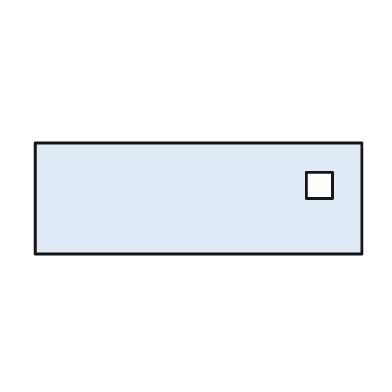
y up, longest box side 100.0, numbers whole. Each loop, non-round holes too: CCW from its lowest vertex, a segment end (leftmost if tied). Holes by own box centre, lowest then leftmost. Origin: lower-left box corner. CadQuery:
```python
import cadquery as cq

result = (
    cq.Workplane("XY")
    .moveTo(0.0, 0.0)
    .lineTo(100.0, 0.0)
    .lineTo(100.0, 34.0)
    .lineTo(0.0, 34.0)
    .close()
    .moveTo(83.0, 17.0)
    .lineTo(91.0, 17.0)
    .lineTo(91.0, 25.0)
    .lineTo(83.0, 25.0)
    .close()
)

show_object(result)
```